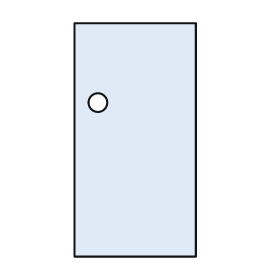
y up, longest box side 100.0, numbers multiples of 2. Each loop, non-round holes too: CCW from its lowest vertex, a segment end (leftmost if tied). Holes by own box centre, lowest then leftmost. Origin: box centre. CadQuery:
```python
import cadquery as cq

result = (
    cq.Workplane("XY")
    .moveTo(-26.0, -50.0)
    .lineTo(26.0, -50.0)
    .lineTo(26.0, 50.0)
    .lineTo(-26.0, 50.0)
    .close()
    .moveTo(-16.0, 16.0)
    .circle(4.0)
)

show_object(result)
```